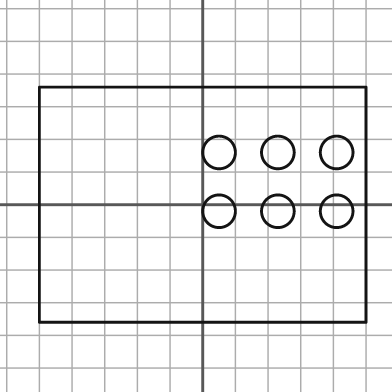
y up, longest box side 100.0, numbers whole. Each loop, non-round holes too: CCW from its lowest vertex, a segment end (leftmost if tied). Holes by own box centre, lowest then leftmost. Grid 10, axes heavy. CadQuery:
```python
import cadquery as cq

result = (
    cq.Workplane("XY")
    .moveTo(-50.0, -36.0)
    .lineTo(50.0, -36.0)
    .lineTo(50.0, 36.0)
    .lineTo(-50.0, 36.0)
    .close()
    .moveTo(5.0, -2.0)
    .circle(5.0)
    .moveTo(23.0, -2.0)
    .circle(5.0)
    .moveTo(41.0, -2.0)
    .circle(5.0)
    .moveTo(5.0, 16.0)
    .circle(5.0)
    .moveTo(23.0, 16.0)
    .circle(5.0)
    .moveTo(41.0, 16.0)
    .circle(5.0)
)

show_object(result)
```